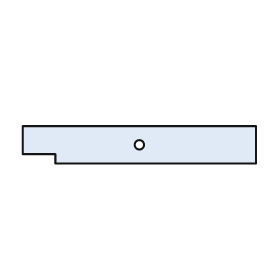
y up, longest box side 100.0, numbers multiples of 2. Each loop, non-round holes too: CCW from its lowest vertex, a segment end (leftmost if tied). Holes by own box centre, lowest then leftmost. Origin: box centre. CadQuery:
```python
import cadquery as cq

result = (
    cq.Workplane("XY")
    .moveTo(-36.0, -8.0)
    .lineTo(50.0, -8.0)
    .lineTo(50.0, 8.0)
    .lineTo(-50.0, 8.0)
    .lineTo(-50.0, -4.0)
    .lineTo(-36.0, -4.0)
    .close()
    .moveTo(0.0, 0.0)
    .circle(2.0)
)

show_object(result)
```